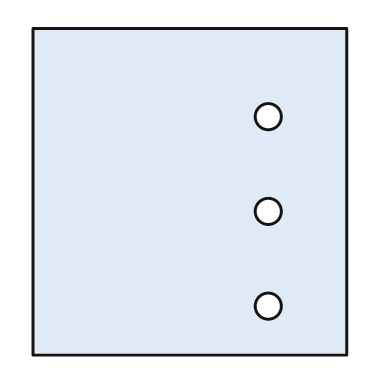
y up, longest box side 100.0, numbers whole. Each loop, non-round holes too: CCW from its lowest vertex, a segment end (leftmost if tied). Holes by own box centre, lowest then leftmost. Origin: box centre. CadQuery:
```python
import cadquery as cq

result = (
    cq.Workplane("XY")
    .moveTo(-48.0, -50.0)
    .lineTo(48.0, -50.0)
    .lineTo(48.0, 50.0)
    .lineTo(-48.0, 50.0)
    .close()
    .moveTo(24.0, -35.0)
    .circle(4.0)
    .moveTo(24.0, -6.0)
    .circle(4.0)
    .moveTo(24.0, 23.0)
    .circle(4.0)
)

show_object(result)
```